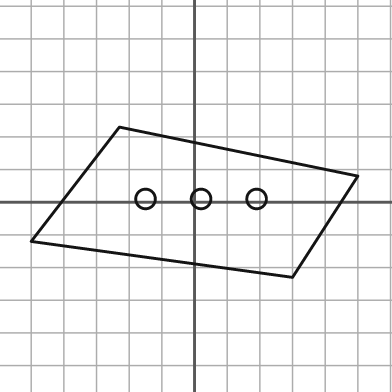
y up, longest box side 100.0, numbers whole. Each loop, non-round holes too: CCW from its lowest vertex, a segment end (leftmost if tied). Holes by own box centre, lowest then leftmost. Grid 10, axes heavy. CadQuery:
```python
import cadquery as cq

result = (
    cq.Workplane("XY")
    .moveTo(30.0, -23.0)
    .lineTo(50.0, 8.0)
    .lineTo(-23.0, 23.0)
    .lineTo(-50.0, -12.0)
    .close()
    .moveTo(-15.0, 1.0)
    .circle(3.0)
    .moveTo(2.0, 1.0)
    .circle(3.0)
    .moveTo(19.0, 1.0)
    .circle(3.0)
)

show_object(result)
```